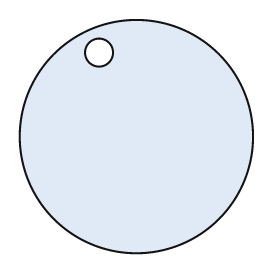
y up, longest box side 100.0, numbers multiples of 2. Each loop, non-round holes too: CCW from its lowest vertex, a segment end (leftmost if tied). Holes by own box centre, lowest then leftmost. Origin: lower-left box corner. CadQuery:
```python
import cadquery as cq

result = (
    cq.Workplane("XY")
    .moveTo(50.0, 50.0)
    .circle(50.0)
    .moveTo(34.0, 86.0)
    .circle(6.0)
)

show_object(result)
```